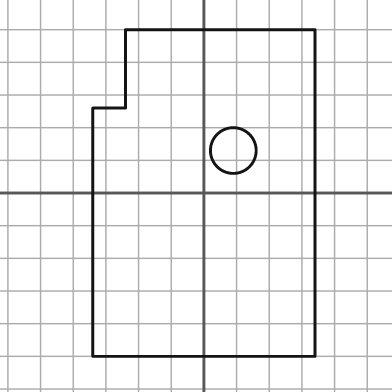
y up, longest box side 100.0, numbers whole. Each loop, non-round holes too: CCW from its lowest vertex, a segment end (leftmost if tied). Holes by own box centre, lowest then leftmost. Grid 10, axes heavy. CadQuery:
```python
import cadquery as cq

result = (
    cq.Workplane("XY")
    .moveTo(-34.0, -50.0)
    .lineTo(34.0, -50.0)
    .lineTo(34.0, 50.0)
    .lineTo(-24.0, 50.0)
    .lineTo(-24.0, 26.0)
    .lineTo(-34.0, 26.0)
    .close()
    .moveTo(9.0, 13.0)
    .circle(7.0)
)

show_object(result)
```